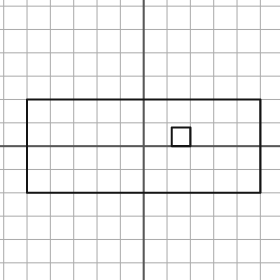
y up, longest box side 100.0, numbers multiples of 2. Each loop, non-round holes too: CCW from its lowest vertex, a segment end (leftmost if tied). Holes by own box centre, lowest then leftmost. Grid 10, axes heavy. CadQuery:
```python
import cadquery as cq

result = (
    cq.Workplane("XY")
    .moveTo(-50.0, -20.0)
    .lineTo(50.0, -20.0)
    .lineTo(50.0, 20.0)
    .lineTo(-50.0, 20.0)
    .close()
    .moveTo(12.0, 0.0)
    .lineTo(20.0, 0.0)
    .lineTo(20.0, 8.0)
    .lineTo(12.0, 8.0)
    .close()
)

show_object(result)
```